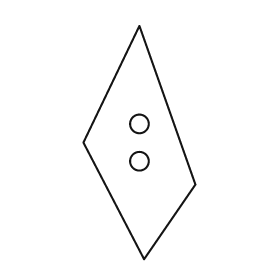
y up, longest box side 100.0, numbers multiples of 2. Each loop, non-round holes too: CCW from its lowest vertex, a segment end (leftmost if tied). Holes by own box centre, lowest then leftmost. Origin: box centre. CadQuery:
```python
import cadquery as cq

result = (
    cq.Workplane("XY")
    .moveTo(2.0, -50.0)
    .lineTo(24.0, -18.0)
    .lineTo(0.0, 50.0)
    .lineTo(-24.0, 0.0)
    .close()
    .moveTo(0.0, -8.0)
    .circle(4.0)
    .moveTo(0.0, 8.0)
    .circle(4.0)
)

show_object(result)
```